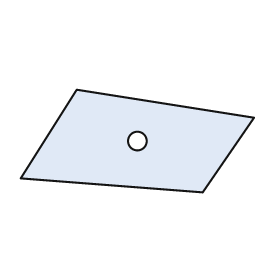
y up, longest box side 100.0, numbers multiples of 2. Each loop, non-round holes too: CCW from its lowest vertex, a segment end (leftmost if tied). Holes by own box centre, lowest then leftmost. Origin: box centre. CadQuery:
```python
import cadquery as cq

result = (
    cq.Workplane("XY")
    .moveTo(28.0, -22.0)
    .lineTo(50.0, 10.0)
    .lineTo(-26.0, 22.0)
    .lineTo(-50.0, -16.0)
    .close()
    .moveTo(0.0, 0.0)
    .circle(4.0)
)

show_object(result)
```